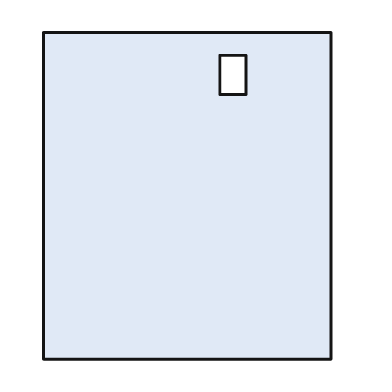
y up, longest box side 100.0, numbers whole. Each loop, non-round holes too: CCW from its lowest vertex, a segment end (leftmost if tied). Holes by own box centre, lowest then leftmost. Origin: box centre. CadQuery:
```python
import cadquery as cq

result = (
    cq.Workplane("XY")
    .moveTo(-44.0, -50.0)
    .lineTo(44.0, -50.0)
    .lineTo(44.0, 50.0)
    .lineTo(-44.0, 50.0)
    .close()
    .moveTo(10.0, 31.0)
    .lineTo(18.0, 31.0)
    .lineTo(18.0, 43.0)
    .lineTo(10.0, 43.0)
    .close()
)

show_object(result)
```